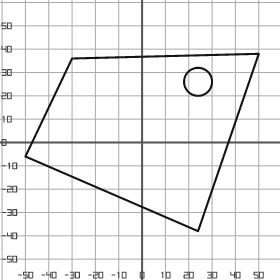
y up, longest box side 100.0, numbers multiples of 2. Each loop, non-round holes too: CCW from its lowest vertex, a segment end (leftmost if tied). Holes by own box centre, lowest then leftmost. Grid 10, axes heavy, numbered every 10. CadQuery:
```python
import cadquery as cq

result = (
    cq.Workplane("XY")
    .moveTo(24.0, -38.0)
    .lineTo(50.0, 38.0)
    .lineTo(-30.0, 36.0)
    .lineTo(-50.0, -6.0)
    .close()
    .moveTo(24.0, 26.0)
    .circle(6.0)
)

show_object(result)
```